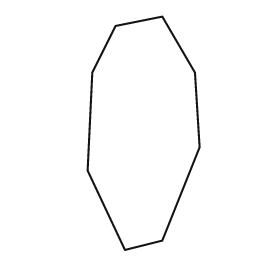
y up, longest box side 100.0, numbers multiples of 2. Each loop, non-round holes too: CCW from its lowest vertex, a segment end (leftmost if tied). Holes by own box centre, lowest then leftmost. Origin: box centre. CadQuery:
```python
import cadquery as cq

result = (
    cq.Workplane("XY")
    .moveTo(-8.0, -50.0)
    .lineTo(8.0, -46.0)
    .lineTo(24.0, -6.0)
    .lineTo(22.0, 26.0)
    .lineTo(8.0, 50.0)
    .lineTo(-12.0, 46.0)
    .lineTo(-22.0, 26.0)
    .lineTo(-24.0, -16.0)
    .close()
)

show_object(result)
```